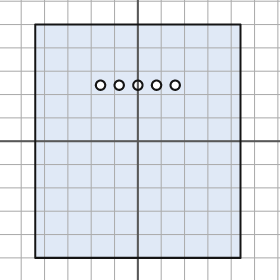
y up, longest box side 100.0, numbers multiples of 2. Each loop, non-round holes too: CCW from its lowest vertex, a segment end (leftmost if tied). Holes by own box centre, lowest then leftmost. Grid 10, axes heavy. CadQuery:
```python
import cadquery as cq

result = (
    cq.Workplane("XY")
    .moveTo(-44.0, -50.0)
    .lineTo(44.0, -50.0)
    .lineTo(44.0, 50.0)
    .lineTo(-44.0, 50.0)
    .close()
    .moveTo(-16.0, 24.0)
    .circle(2.0)
    .moveTo(-8.0, 24.0)
    .circle(2.0)
    .moveTo(0.0, 24.0)
    .circle(2.0)
    .moveTo(8.0, 24.0)
    .circle(2.0)
    .moveTo(16.0, 24.0)
    .circle(2.0)
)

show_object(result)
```